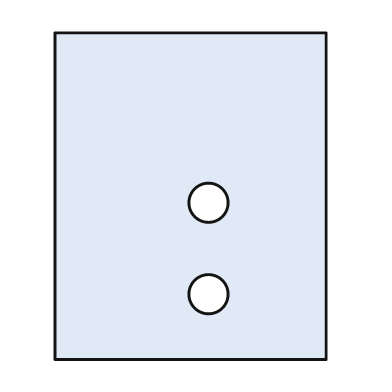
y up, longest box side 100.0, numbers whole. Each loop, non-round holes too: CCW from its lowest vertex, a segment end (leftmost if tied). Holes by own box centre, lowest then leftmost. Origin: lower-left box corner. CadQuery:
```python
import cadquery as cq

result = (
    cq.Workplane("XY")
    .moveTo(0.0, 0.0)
    .lineTo(83.0, 0.0)
    .lineTo(83.0, 100.0)
    .lineTo(0.0, 100.0)
    .close()
    .moveTo(47.0, 20.0)
    .circle(6.0)
    .moveTo(47.0, 48.0)
    .circle(6.0)
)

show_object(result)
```